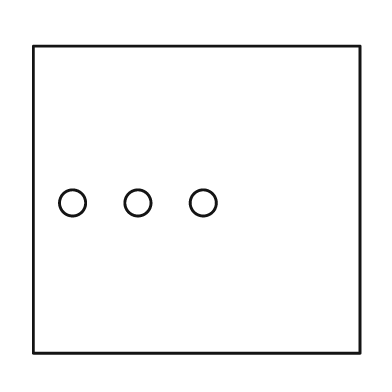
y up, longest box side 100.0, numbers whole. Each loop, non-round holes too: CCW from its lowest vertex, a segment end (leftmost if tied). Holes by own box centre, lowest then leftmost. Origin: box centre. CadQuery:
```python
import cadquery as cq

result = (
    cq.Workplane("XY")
    .moveTo(-50.0, -47.0)
    .lineTo(50.0, -47.0)
    .lineTo(50.0, 47.0)
    .lineTo(-50.0, 47.0)
    .close()
    .moveTo(-38.0, -1.0)
    .circle(4.0)
    .moveTo(-18.0, -1.0)
    .circle(4.0)
    .moveTo(2.0, -1.0)
    .circle(4.0)
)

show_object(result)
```